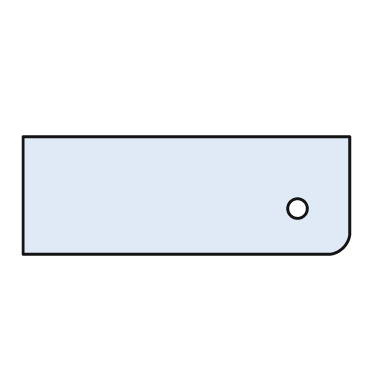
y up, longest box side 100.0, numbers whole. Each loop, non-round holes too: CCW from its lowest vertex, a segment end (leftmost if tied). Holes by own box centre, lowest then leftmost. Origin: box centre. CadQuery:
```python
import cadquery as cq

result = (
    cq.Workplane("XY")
    .moveTo(-50.0, -18.0)
    .lineTo(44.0, -18.0)
    .threePointArc((48.0, -16.0), (50.0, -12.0))
    .lineTo(50.0, 18.0)
    .lineTo(-50.0, 18.0)
    .close()
    .moveTo(34.0, -4.0)
    .circle(3.0)
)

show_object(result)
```